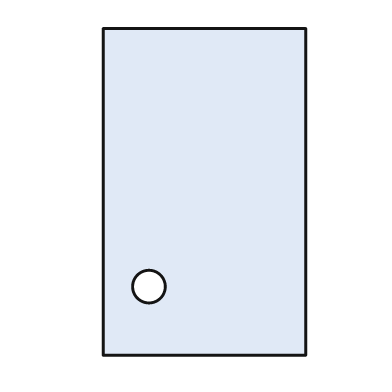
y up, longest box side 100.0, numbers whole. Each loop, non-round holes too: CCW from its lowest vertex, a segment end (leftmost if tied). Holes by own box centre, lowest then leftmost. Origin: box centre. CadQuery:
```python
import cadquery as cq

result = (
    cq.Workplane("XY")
    .moveTo(-31.0, -50.0)
    .lineTo(31.0, -50.0)
    .lineTo(31.0, 50.0)
    .lineTo(-31.0, 50.0)
    .close()
    .moveTo(-17.0, -29.0)
    .circle(5.0)
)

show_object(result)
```